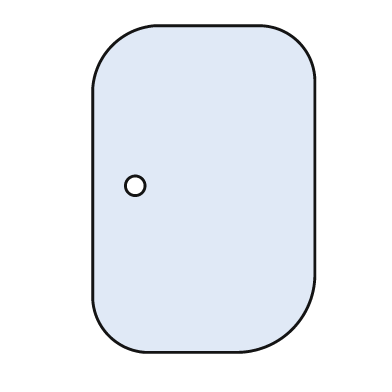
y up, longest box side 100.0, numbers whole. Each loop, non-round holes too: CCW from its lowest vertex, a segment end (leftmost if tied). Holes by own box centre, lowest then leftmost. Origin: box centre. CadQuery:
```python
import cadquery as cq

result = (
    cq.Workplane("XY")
    .moveTo(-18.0, -50.0)
    .lineTo(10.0, -50.0)
    .threePointArc((27.0, -43.0), (34.0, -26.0))
    .lineTo(34.0, 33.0)
    .threePointArc((29.0, 45.0), (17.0, 50.0))
    .lineTo(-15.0, 50.0)
    .threePointArc((-28.0, 44.0), (-34.0, 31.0))
    .lineTo(-34.0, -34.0)
    .threePointArc((-29.0, -45.0), (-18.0, -50.0))
    .close()
    .moveTo(-21.0, 1.0)
    .circle(3.0)
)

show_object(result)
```